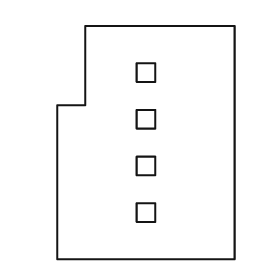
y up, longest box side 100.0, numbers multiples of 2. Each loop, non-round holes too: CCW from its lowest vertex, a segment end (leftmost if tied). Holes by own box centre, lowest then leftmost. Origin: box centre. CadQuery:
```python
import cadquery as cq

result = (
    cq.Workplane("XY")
    .moveTo(-38.0, -50.0)
    .lineTo(38.0, -50.0)
    .lineTo(38.0, 50.0)
    .lineTo(-26.0, 50.0)
    .lineTo(-26.0, 16.0)
    .lineTo(-38.0, 16.0)
    .close()
    .moveTo(-4.0, -34.0)
    .lineTo(4.0, -34.0)
    .lineTo(4.0, -26.0)
    .lineTo(-4.0, -26.0)
    .close()
    .moveTo(-4.0, -14.0)
    .lineTo(4.0, -14.0)
    .lineTo(4.0, -6.0)
    .lineTo(-4.0, -6.0)
    .close()
    .moveTo(-4.0, 6.0)
    .lineTo(4.0, 6.0)
    .lineTo(4.0, 14.0)
    .lineTo(-4.0, 14.0)
    .close()
    .moveTo(-4.0, 26.0)
    .lineTo(4.0, 26.0)
    .lineTo(4.0, 34.0)
    .lineTo(-4.0, 34.0)
    .close()
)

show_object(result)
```